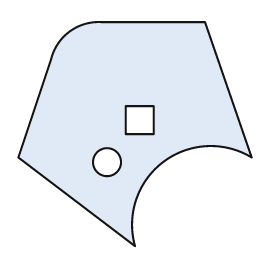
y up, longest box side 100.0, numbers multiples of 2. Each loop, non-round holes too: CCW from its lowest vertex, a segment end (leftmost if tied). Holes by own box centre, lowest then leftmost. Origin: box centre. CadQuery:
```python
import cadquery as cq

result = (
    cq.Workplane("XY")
    .moveTo(0.0, -48.0)
    .threePointArc((12.0, -12.0), (50.0, -10.0))
    .lineTo(30.0, 48.0)
    .lineTo(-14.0, 48.0)
    .threePointArc((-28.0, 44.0), (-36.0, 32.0))
    .lineTo(-50.0, -10.0)
    .close()
    .moveTo(-12.0, -12.0)
    .circle(6.0)
    .moveTo(-4.0, 0.0)
    .lineTo(8.0, 0.0)
    .lineTo(8.0, 12.0)
    .lineTo(-4.0, 12.0)
    .close()
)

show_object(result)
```